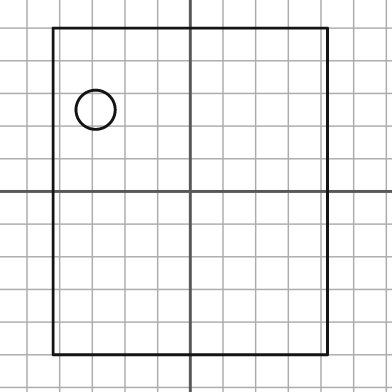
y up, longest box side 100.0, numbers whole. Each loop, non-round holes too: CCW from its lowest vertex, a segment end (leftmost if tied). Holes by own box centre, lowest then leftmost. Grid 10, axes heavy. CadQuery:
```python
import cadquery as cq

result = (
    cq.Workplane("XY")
    .moveTo(-42.0, -50.0)
    .lineTo(42.0, -50.0)
    .lineTo(42.0, 50.0)
    .lineTo(-42.0, 50.0)
    .close()
    .moveTo(-29.0, 25.0)
    .circle(6.0)
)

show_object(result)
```